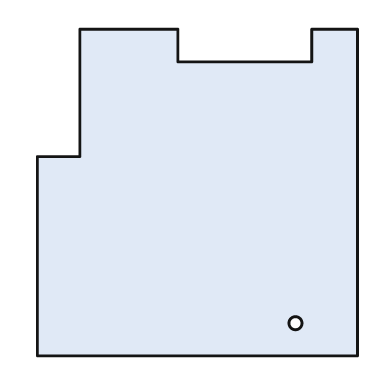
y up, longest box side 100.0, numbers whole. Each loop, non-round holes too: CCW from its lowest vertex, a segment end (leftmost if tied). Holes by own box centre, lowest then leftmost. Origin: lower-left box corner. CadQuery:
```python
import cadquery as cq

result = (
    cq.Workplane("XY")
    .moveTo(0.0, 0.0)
    .lineTo(98.0, 0.0)
    .lineTo(98.0, 100.0)
    .lineTo(84.0, 100.0)
    .lineTo(84.0, 90.0)
    .lineTo(43.0, 90.0)
    .lineTo(43.0, 100.0)
    .lineTo(13.0, 100.0)
    .lineTo(13.0, 61.0)
    .lineTo(0.0, 61.0)
    .close()
    .moveTo(79.0, 10.0)
    .circle(2.0)
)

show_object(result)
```